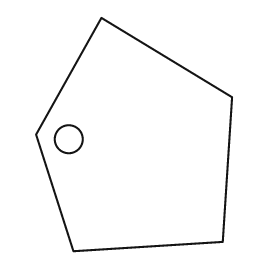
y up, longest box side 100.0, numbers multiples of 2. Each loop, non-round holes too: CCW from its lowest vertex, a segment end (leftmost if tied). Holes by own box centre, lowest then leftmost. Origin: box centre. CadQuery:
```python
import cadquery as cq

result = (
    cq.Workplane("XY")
    .moveTo(-26.0, -50.0)
    .lineTo(38.0, -46.0)
    .lineTo(42.0, 16.0)
    .lineTo(-14.0, 50.0)
    .lineTo(-42.0, 0.0)
    .close()
    .moveTo(-28.0, -2.0)
    .circle(6.0)
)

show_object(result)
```